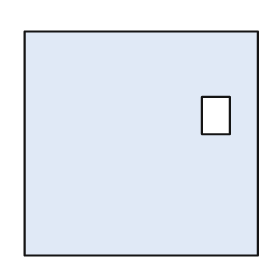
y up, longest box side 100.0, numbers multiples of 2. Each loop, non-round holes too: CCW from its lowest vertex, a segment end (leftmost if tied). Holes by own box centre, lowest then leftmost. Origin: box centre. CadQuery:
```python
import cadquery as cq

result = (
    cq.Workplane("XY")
    .moveTo(-50.0, -48.0)
    .lineTo(50.0, -48.0)
    .lineTo(50.0, 48.0)
    .lineTo(-50.0, 48.0)
    .close()
    .moveTo(26.0, 4.0)
    .lineTo(38.0, 4.0)
    .lineTo(38.0, 20.0)
    .lineTo(26.0, 20.0)
    .close()
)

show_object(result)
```